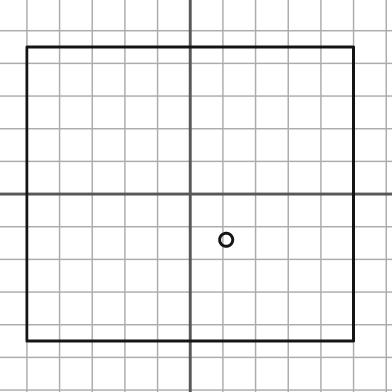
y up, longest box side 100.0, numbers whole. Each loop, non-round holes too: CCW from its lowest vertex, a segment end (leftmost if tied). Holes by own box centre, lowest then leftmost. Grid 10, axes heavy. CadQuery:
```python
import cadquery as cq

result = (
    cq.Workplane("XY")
    .moveTo(-50.0, -45.0)
    .lineTo(50.0, -45.0)
    .lineTo(50.0, 45.0)
    .lineTo(-50.0, 45.0)
    .close()
    .moveTo(11.0, -14.0)
    .circle(2.0)
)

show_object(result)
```